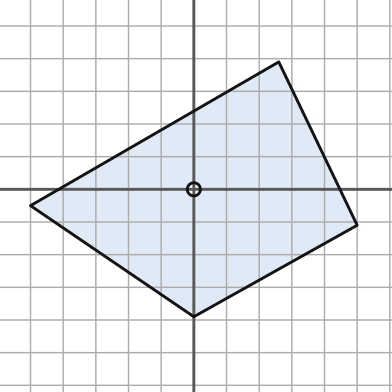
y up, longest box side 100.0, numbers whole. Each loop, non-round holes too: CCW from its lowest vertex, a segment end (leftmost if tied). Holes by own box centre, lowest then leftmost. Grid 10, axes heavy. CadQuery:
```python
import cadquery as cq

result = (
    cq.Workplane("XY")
    .moveTo(0.0, -39.0)
    .lineTo(50.0, -11.0)
    .lineTo(26.0, 39.0)
    .lineTo(-50.0, -5.0)
    .close()
    .moveTo(0.0, 0.0)
    .circle(2.0)
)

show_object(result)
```